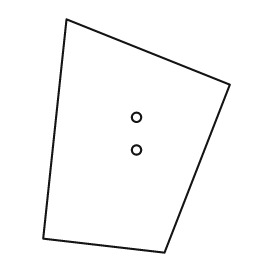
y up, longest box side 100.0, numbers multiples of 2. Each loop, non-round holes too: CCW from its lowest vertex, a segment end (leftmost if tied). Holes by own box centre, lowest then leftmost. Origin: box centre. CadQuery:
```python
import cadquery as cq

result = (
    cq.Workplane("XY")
    .moveTo(12.0, -50.0)
    .lineTo(40.0, 22.0)
    .lineTo(-30.0, 50.0)
    .lineTo(-40.0, -44.0)
    .close()
    .moveTo(0.0, -6.0)
    .circle(2.0)
    .moveTo(0.0, 8.0)
    .circle(2.0)
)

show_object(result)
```